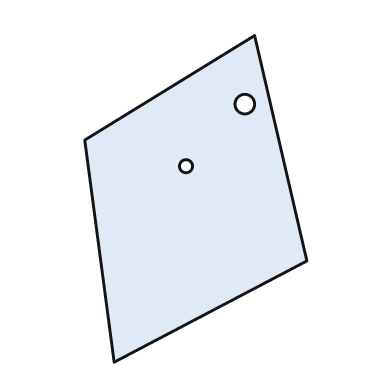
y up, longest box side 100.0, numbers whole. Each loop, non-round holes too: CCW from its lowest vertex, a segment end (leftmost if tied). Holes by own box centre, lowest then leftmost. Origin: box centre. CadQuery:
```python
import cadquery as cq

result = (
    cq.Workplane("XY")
    .moveTo(-25.0, -50.0)
    .lineTo(34.0, -19.0)
    .lineTo(18.0, 50.0)
    .lineTo(-34.0, 18.0)
    .close()
    .moveTo(-3.0, 10.0)
    .circle(2.0)
    .moveTo(15.0, 29.0)
    .circle(3.0)
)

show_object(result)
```